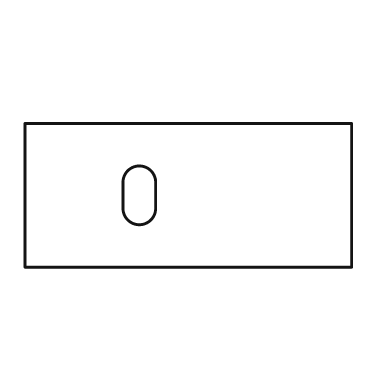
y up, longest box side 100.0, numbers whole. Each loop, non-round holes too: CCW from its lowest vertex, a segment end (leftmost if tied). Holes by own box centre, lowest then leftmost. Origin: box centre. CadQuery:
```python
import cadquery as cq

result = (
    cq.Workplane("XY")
    .moveTo(-50.0, -22.0)
    .lineTo(50.0, -22.0)
    .lineTo(50.0, 22.0)
    .lineTo(-50.0, 22.0)
    .close()
    .moveTo(-20.0, -4.0)
    .threePointArc((-15.0, -9.0), (-10.0, -4.0))
    .lineTo(-10.0, 4.0)
    .threePointArc((-15.0, 9.0), (-20.0, 4.0))
    .close()
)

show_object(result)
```